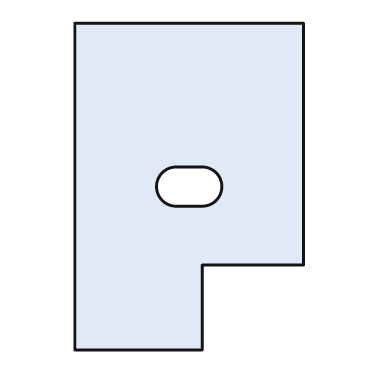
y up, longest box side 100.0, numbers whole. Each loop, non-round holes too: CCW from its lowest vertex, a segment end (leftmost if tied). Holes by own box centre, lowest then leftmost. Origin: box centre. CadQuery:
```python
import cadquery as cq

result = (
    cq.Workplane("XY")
    .moveTo(-35.0, -50.0)
    .lineTo(4.0, -50.0)
    .lineTo(4.0, -24.0)
    .lineTo(35.0, -24.0)
    .lineTo(35.0, 50.0)
    .lineTo(-35.0, 50.0)
    .close()
    .moveTo(-4.0, -6.0)
    .lineTo(4.0, -6.0)
    .threePointArc((10.0, 0.0), (4.0, 6.0))
    .lineTo(-4.0, 6.0)
    .threePointArc((-10.0, 0.0), (-4.0, -6.0))
    .close()
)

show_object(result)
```